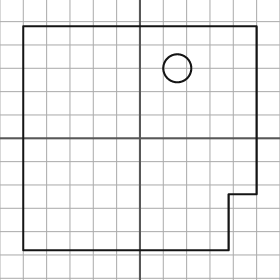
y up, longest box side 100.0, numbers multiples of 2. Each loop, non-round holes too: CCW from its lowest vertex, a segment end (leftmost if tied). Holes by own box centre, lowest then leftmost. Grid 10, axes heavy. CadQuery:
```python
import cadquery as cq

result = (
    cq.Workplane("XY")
    .moveTo(-50.0, -48.0)
    .lineTo(38.0, -48.0)
    .lineTo(38.0, -24.0)
    .lineTo(50.0, -24.0)
    .lineTo(50.0, 48.0)
    .lineTo(-50.0, 48.0)
    .close()
    .moveTo(16.0, 30.0)
    .circle(6.0)
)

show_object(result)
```